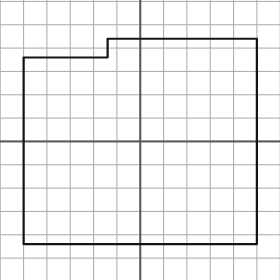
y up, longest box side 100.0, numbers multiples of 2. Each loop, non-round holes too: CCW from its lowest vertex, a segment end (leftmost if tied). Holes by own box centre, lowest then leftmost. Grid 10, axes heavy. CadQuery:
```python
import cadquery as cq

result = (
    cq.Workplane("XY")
    .moveTo(-50.0, -44.0)
    .lineTo(50.0, -44.0)
    .lineTo(50.0, 44.0)
    .lineTo(-14.0, 44.0)
    .lineTo(-14.0, 36.0)
    .lineTo(-50.0, 36.0)
    .close()
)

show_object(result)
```